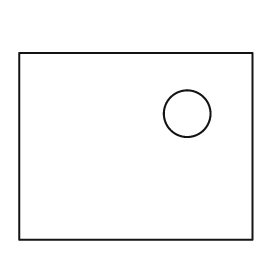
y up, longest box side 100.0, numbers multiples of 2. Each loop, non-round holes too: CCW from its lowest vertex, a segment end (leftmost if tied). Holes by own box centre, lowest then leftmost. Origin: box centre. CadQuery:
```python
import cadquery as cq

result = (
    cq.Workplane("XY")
    .moveTo(-50.0, -40.0)
    .lineTo(50.0, -40.0)
    .lineTo(50.0, 40.0)
    .lineTo(-50.0, 40.0)
    .close()
    .moveTo(22.0, 14.0)
    .circle(10.0)
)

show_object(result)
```